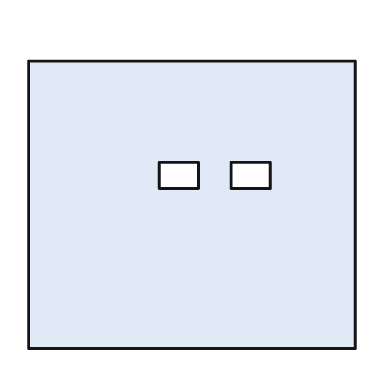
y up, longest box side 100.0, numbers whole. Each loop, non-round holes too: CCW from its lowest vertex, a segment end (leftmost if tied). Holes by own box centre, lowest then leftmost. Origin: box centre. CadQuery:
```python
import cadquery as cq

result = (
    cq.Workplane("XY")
    .moveTo(-50.0, -44.0)
    .lineTo(50.0, -44.0)
    .lineTo(50.0, 44.0)
    .lineTo(-50.0, 44.0)
    .close()
    .moveTo(-10.0, 5.0)
    .lineTo(2.0, 5.0)
    .lineTo(2.0, 13.0)
    .lineTo(-10.0, 13.0)
    .close()
    .moveTo(12.0, 5.0)
    .lineTo(24.0, 5.0)
    .lineTo(24.0, 13.0)
    .lineTo(12.0, 13.0)
    .close()
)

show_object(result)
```